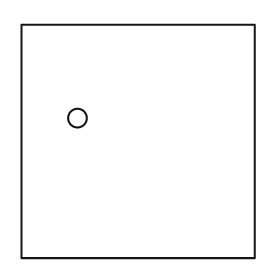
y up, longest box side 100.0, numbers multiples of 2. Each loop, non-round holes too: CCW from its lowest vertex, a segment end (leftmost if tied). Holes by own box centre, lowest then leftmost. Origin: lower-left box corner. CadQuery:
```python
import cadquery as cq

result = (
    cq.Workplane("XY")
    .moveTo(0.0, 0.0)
    .lineTo(100.0, 0.0)
    .lineTo(100.0, 100.0)
    .lineTo(0.0, 100.0)
    .close()
    .moveTo(24.0, 60.0)
    .circle(4.0)
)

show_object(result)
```